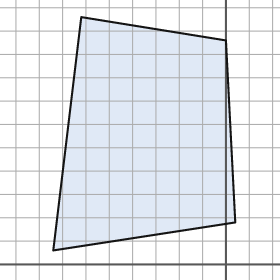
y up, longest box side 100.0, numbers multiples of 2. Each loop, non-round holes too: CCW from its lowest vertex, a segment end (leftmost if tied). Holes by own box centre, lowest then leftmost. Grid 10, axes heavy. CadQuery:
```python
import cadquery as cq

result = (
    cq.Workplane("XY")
    .moveTo(-74.0, 6.0)
    .lineTo(4.0, 18.0)
    .lineTo(0.0, 96.0)
    .lineTo(-62.0, 106.0)
    .close()
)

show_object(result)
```